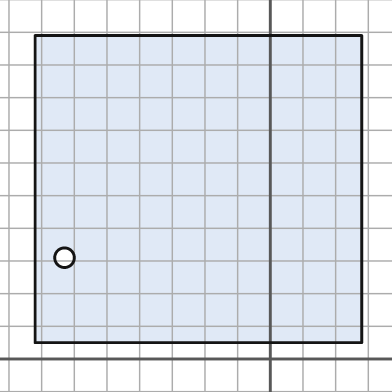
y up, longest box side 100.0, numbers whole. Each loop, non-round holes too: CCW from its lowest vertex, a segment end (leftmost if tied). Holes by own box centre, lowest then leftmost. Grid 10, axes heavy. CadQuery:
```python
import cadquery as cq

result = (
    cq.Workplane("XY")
    .moveTo(-72.0, 5.0)
    .lineTo(28.0, 5.0)
    .lineTo(28.0, 99.0)
    .lineTo(-72.0, 99.0)
    .close()
    .moveTo(-63.0, 31.0)
    .circle(3.0)
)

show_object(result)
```